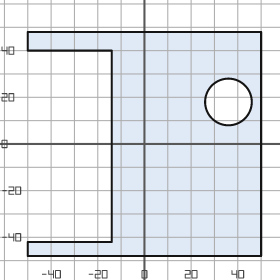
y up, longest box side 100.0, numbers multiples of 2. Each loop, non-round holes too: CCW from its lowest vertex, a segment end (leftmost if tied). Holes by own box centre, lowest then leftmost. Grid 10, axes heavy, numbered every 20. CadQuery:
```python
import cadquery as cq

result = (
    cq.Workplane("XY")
    .moveTo(-50.0, -48.0)
    .lineTo(50.0, -48.0)
    .lineTo(50.0, 48.0)
    .lineTo(-50.0, 48.0)
    .lineTo(-50.0, 40.0)
    .lineTo(-14.0, 40.0)
    .lineTo(-14.0, -42.0)
    .lineTo(-50.0, -42.0)
    .close()
    .moveTo(36.0, 18.0)
    .circle(10.0)
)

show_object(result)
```